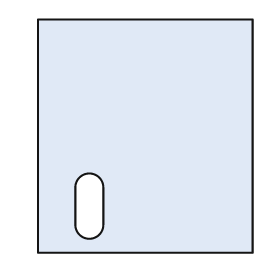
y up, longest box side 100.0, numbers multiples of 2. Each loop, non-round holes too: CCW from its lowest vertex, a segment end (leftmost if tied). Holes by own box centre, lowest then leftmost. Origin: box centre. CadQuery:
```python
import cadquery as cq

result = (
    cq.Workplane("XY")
    .moveTo(-46.0, -50.0)
    .lineTo(46.0, -50.0)
    .lineTo(46.0, 50.0)
    .lineTo(-46.0, 50.0)
    .close()
    .moveTo(-30.0, -38.0)
    .threePointArc((-24.0, -44.0), (-18.0, -38.0))
    .lineTo(-18.0, -22.0)
    .threePointArc((-24.0, -16.0), (-30.0, -22.0))
    .close()
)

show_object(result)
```